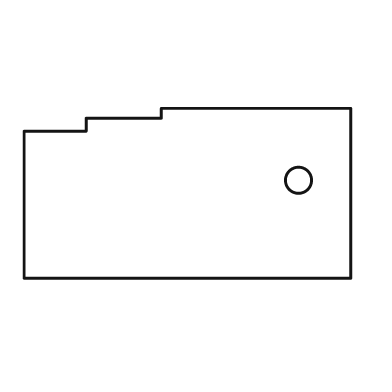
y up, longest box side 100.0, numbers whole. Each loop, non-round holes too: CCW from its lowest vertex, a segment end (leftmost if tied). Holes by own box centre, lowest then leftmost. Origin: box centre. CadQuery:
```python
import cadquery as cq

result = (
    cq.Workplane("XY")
    .moveTo(-50.0, -26.0)
    .lineTo(50.0, -26.0)
    .lineTo(50.0, 26.0)
    .lineTo(-8.0, 26.0)
    .lineTo(-8.0, 23.0)
    .lineTo(-31.0, 23.0)
    .lineTo(-31.0, 19.0)
    .lineTo(-50.0, 19.0)
    .close()
    .moveTo(34.0, 4.0)
    .circle(4.0)
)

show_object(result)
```